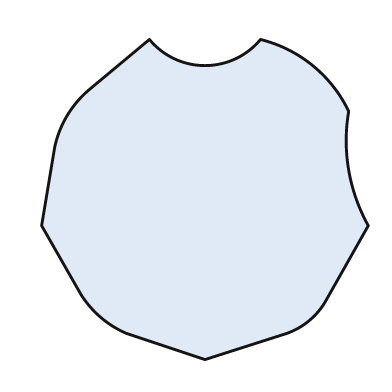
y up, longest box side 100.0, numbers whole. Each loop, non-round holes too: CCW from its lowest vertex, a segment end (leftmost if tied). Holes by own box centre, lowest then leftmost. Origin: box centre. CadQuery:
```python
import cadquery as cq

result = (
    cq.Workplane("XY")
    .moveTo(0.0, -49.0)
    .lineTo(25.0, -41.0)
    .threePointArc((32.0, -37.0), (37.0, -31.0))
    .lineTo(50.0, -8.0)
    .threePointArc((44.0, 9.0), (44.0, 27.0))
    .threePointArc((33.0, 41.0), (17.0, 49.0))
    .threePointArc((0.0, 41.0), (-17.0, 49.0))
    .lineTo(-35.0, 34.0)
    .threePointArc((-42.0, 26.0), (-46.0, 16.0))
    .lineTo(-50.0, -8.0)
    .lineTo(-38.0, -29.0)
    .threePointArc((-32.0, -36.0), (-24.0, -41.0))
    .close()
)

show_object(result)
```